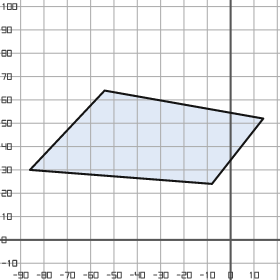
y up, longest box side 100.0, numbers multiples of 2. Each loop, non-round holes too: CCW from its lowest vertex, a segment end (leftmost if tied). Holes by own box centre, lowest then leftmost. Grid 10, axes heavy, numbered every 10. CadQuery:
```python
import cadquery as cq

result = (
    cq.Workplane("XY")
    .moveTo(-8.0, 24.0)
    .lineTo(14.0, 52.0)
    .lineTo(-54.0, 64.0)
    .lineTo(-86.0, 30.0)
    .close()
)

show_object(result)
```